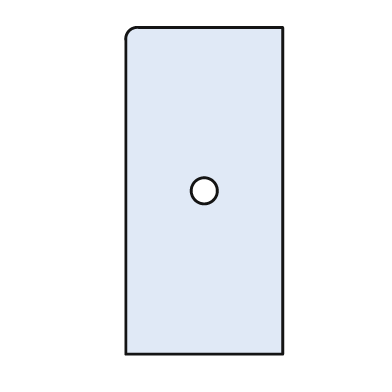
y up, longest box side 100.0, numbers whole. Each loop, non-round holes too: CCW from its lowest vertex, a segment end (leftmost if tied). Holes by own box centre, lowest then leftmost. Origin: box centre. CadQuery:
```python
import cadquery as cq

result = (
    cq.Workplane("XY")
    .moveTo(-24.0, -50.0)
    .lineTo(24.0, -50.0)
    .lineTo(24.0, 50.0)
    .lineTo(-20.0, 50.0)
    .threePointArc((-23.0, 49.0), (-24.0, 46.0))
    .close()
    .moveTo(0.0, 0.0)
    .circle(4.0)
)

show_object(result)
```